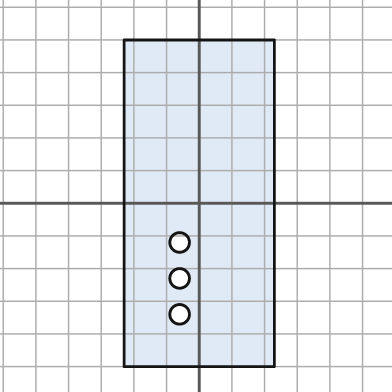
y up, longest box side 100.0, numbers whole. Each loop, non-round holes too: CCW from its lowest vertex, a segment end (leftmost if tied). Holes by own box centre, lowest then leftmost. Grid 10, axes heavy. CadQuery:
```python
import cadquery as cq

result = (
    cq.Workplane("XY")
    .moveTo(-23.0, -50.0)
    .lineTo(23.0, -50.0)
    .lineTo(23.0, 50.0)
    .lineTo(-23.0, 50.0)
    .close()
    .moveTo(-6.0, -34.0)
    .circle(3.0)
    .moveTo(-6.0, -23.0)
    .circle(3.0)
    .moveTo(-6.0, -12.0)
    .circle(3.0)
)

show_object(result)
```